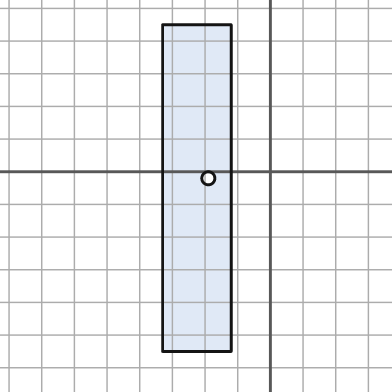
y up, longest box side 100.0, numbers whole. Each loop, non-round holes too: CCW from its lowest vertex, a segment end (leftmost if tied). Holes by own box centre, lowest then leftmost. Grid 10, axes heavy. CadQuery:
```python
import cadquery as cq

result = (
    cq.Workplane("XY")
    .moveTo(-33.0, -55.0)
    .lineTo(-12.0, -55.0)
    .lineTo(-12.0, 45.0)
    .lineTo(-33.0, 45.0)
    .close()
    .moveTo(-19.0, -2.0)
    .circle(2.0)
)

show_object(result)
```